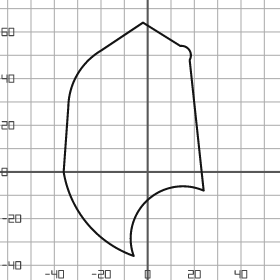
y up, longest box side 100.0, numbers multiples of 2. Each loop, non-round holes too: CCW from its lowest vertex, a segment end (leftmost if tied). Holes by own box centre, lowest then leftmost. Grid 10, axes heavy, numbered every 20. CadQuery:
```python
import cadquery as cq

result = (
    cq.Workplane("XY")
    .moveTo(-6.0, -36.0)
    .threePointArc((0.0, -12.0), (24.0, -8.0))
    .lineTo(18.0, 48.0)
    .threePointArc((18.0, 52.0), (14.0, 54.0))
    .lineTo(-2.0, 64.0)
    .lineTo(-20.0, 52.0)
    .threePointArc((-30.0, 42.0), (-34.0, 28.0))
    .lineTo(-36.0, 0.0)
    .threePointArc((-26.0, -22.0), (-6.0, -36.0))
    .close()
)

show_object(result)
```